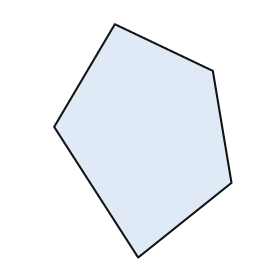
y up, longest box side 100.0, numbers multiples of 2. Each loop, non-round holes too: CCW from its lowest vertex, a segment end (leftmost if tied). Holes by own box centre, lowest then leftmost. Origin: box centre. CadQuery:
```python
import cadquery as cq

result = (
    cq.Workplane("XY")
    .moveTo(-2.0, -50.0)
    .lineTo(38.0, -18.0)
    .lineTo(30.0, 30.0)
    .lineTo(-12.0, 50.0)
    .lineTo(-38.0, 6.0)
    .close()
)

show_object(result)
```